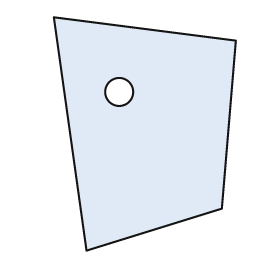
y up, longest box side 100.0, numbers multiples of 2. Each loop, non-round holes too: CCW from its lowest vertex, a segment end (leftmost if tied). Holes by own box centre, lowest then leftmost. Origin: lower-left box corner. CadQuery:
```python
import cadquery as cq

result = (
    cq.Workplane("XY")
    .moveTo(14.0, 0.0)
    .lineTo(72.0, 18.0)
    .lineTo(78.0, 90.0)
    .lineTo(0.0, 100.0)
    .close()
    .moveTo(28.0, 68.0)
    .circle(6.0)
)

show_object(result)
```